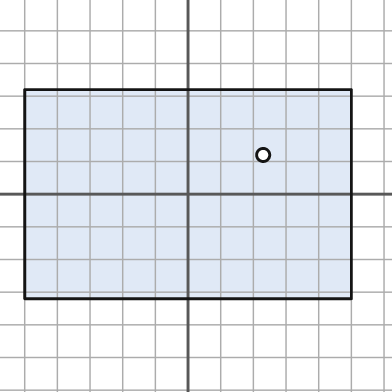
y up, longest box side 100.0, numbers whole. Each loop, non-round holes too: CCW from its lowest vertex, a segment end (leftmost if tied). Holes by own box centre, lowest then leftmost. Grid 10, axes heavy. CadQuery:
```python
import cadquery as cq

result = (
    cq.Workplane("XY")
    .moveTo(-50.0, -32.0)
    .lineTo(50.0, -32.0)
    .lineTo(50.0, 32.0)
    .lineTo(-50.0, 32.0)
    .close()
    .moveTo(23.0, 12.0)
    .circle(2.0)
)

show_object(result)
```